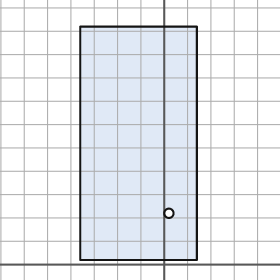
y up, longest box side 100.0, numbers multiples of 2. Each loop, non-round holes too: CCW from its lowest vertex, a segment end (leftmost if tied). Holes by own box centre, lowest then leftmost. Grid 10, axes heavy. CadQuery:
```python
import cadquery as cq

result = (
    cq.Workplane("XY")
    .moveTo(-36.0, 2.0)
    .lineTo(14.0, 2.0)
    .lineTo(14.0, 102.0)
    .lineTo(-36.0, 102.0)
    .close()
    .moveTo(2.0, 22.0)
    .circle(2.0)
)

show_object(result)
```